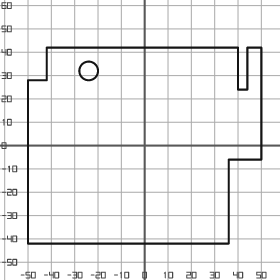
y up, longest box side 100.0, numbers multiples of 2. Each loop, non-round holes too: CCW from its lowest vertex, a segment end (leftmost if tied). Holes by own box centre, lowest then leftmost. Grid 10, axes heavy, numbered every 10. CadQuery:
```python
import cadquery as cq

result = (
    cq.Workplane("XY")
    .moveTo(-50.0, -42.0)
    .lineTo(36.0, -42.0)
    .lineTo(36.0, -6.0)
    .lineTo(50.0, -6.0)
    .lineTo(50.0, 42.0)
    .lineTo(44.0, 42.0)
    .lineTo(44.0, 24.0)
    .lineTo(40.0, 24.0)
    .lineTo(40.0, 42.0)
    .lineTo(-42.0, 42.0)
    .lineTo(-42.0, 28.0)
    .lineTo(-50.0, 28.0)
    .close()
    .moveTo(-24.0, 32.0)
    .circle(4.0)
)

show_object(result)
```